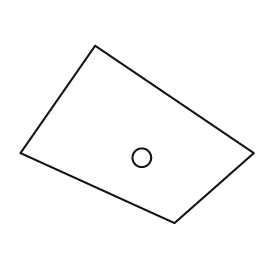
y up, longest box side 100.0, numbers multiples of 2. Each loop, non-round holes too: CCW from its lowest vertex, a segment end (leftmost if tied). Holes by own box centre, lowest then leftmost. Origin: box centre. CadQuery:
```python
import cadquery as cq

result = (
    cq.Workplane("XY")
    .moveTo(16.0, -38.0)
    .lineTo(50.0, -8.0)
    .lineTo(-18.0, 38.0)
    .lineTo(-50.0, -8.0)
    .close()
    .moveTo(2.0, -10.0)
    .circle(4.0)
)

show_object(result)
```